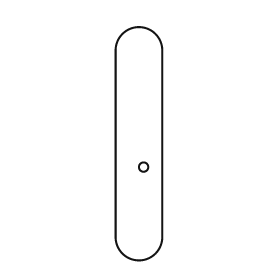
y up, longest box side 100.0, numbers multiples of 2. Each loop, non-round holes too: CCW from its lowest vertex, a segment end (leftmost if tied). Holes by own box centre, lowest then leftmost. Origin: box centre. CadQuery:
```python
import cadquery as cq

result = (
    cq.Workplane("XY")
    .moveTo(-10.0, -40.0)
    .threePointArc((0.0, -50.0), (10.0, -40.0))
    .lineTo(10.0, 40.0)
    .threePointArc((0.0, 50.0), (-10.0, 40.0))
    .close()
    .moveTo(2.0, -10.0)
    .circle(2.0)
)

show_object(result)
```